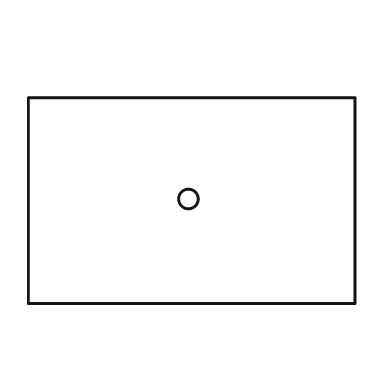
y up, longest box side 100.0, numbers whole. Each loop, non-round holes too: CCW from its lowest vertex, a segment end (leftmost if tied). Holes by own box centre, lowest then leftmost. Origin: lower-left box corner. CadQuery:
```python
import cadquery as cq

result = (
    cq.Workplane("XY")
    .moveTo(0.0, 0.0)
    .lineTo(100.0, 0.0)
    .lineTo(100.0, 63.0)
    .lineTo(0.0, 63.0)
    .close()
    .moveTo(49.0, 32.0)
    .circle(3.0)
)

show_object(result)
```